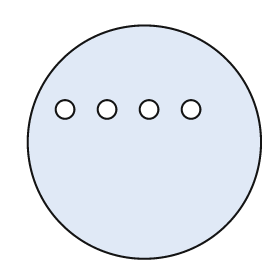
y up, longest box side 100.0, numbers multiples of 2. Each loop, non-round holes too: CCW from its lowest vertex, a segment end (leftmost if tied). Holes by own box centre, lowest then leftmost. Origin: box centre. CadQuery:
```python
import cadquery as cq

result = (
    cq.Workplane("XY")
    .moveTo(0.0, 0.0)
    .circle(50.0)
    .moveTo(-34.0, 14.0)
    .circle(4.0)
    .moveTo(-16.0, 14.0)
    .circle(4.0)
    .moveTo(2.0, 14.0)
    .circle(4.0)
    .moveTo(20.0, 14.0)
    .circle(4.0)
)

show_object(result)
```